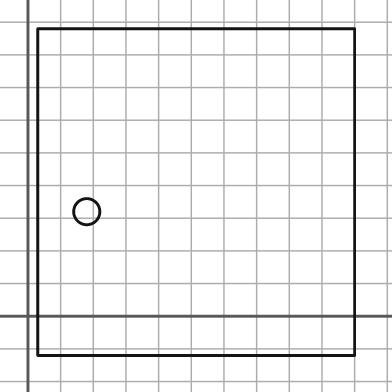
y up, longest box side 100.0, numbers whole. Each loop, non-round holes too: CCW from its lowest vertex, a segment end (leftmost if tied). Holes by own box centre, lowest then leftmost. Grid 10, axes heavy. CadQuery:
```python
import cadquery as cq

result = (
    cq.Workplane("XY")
    .moveTo(3.0, -12.0)
    .lineTo(100.0, -12.0)
    .lineTo(100.0, 88.0)
    .lineTo(3.0, 88.0)
    .close()
    .moveTo(18.0, 32.0)
    .circle(4.0)
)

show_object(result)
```